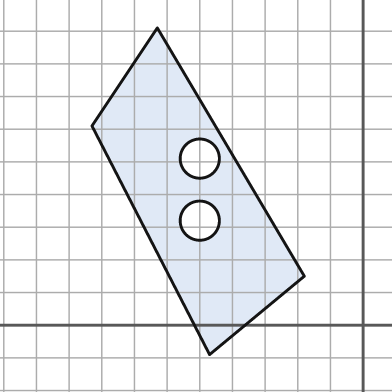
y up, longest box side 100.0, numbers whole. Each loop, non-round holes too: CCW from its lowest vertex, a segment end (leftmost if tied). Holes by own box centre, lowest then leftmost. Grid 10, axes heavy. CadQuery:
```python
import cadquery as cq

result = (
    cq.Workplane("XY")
    .moveTo(-47.0, -9.0)
    .lineTo(-18.0, 15.0)
    .lineTo(-63.0, 91.0)
    .lineTo(-83.0, 61.0)
    .close()
    .moveTo(-50.0, 32.0)
    .circle(6.0)
    .moveTo(-50.0, 51.0)
    .circle(6.0)
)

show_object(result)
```